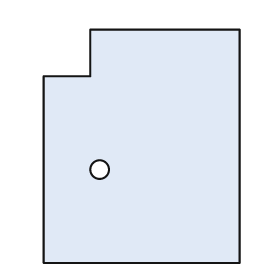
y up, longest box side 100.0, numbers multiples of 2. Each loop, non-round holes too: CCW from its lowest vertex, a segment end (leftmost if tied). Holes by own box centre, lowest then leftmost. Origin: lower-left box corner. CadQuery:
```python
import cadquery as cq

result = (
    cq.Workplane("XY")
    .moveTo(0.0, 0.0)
    .lineTo(84.0, 0.0)
    .lineTo(84.0, 100.0)
    .lineTo(20.0, 100.0)
    .lineTo(20.0, 80.0)
    .lineTo(0.0, 80.0)
    .close()
    .moveTo(24.0, 40.0)
    .circle(4.0)
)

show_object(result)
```